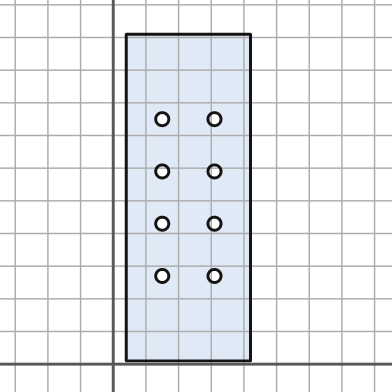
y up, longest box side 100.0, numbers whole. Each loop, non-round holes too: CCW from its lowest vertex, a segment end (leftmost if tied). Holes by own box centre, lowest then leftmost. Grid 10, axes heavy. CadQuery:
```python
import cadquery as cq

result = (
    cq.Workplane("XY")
    .moveTo(4.0, 1.0)
    .lineTo(42.0, 1.0)
    .lineTo(42.0, 101.0)
    .lineTo(4.0, 101.0)
    .close()
    .moveTo(15.0, 27.0)
    .circle(2.0)
    .moveTo(31.0, 27.0)
    .circle(2.0)
    .moveTo(15.0, 43.0)
    .circle(2.0)
    .moveTo(31.0, 43.0)
    .circle(2.0)
    .moveTo(15.0, 59.0)
    .circle(2.0)
    .moveTo(31.0, 59.0)
    .circle(2.0)
    .moveTo(15.0, 75.0)
    .circle(2.0)
    .moveTo(31.0, 75.0)
    .circle(2.0)
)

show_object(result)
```